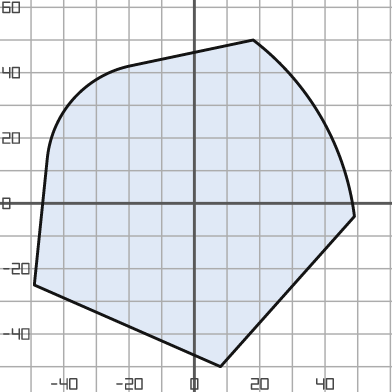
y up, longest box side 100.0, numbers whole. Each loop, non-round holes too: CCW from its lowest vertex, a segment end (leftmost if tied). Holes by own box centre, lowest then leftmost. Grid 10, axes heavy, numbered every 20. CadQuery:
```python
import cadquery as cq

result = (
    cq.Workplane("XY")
    .moveTo(8.0, -50.0)
    .lineTo(49.0, -4.0)
    .threePointArc((39.0, 26.0), (18.0, 50.0))
    .lineTo(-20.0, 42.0)
    .threePointArc((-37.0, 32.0), (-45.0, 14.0))
    .lineTo(-49.0, -25.0)
    .close()
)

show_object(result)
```